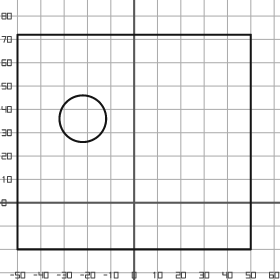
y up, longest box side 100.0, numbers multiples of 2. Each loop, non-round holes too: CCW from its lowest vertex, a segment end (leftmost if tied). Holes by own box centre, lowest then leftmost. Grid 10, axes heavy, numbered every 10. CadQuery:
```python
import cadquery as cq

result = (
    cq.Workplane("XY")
    .moveTo(-50.0, -20.0)
    .lineTo(50.0, -20.0)
    .lineTo(50.0, 72.0)
    .lineTo(-50.0, 72.0)
    .close()
    .moveTo(-22.0, 36.0)
    .circle(10.0)
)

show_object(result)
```